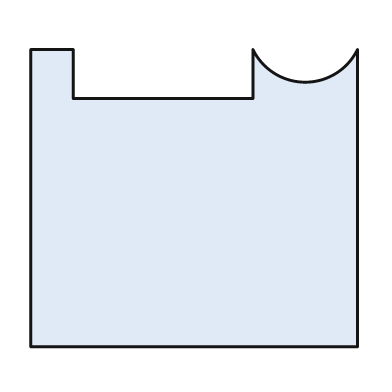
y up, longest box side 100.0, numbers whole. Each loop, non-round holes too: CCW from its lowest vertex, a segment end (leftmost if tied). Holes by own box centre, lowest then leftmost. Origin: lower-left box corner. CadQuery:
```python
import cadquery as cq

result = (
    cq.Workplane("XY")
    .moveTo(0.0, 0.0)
    .lineTo(100.0, 0.0)
    .lineTo(100.0, 91.0)
    .threePointArc((84.0, 81.0), (68.0, 91.0))
    .lineTo(68.0, 76.0)
    .lineTo(13.0, 76.0)
    .lineTo(13.0, 91.0)
    .lineTo(0.0, 91.0)
    .close()
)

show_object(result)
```